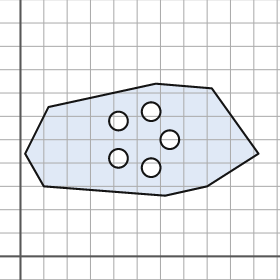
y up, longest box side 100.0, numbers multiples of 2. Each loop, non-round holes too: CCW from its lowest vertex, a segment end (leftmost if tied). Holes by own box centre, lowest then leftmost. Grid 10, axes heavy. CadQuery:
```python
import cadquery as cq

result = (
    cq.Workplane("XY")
    .moveTo(62.0, 26.0)
    .lineTo(80.0, 30.0)
    .lineTo(102.0, 44.0)
    .lineTo(82.0, 72.0)
    .lineTo(58.0, 74.0)
    .lineTo(12.0, 64.0)
    .lineTo(2.0, 44.0)
    .lineTo(10.0, 30.0)
    .close()
    .moveTo(56.0, 38.0)
    .circle(4.0)
    .moveTo(42.0, 42.0)
    .circle(4.0)
    .moveTo(64.0, 50.0)
    .circle(4.0)
    .moveTo(42.0, 58.0)
    .circle(4.0)
    .moveTo(56.0, 62.0)
    .circle(4.0)
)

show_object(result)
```